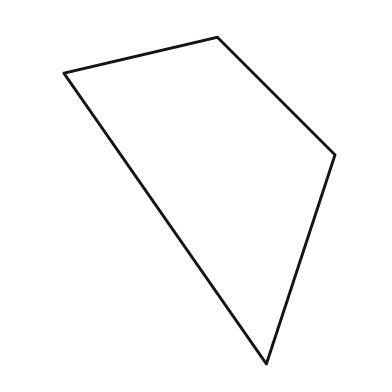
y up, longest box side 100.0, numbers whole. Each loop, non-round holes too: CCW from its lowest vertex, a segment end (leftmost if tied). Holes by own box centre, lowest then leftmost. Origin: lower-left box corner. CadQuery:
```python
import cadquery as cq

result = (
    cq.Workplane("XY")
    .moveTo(62.0, 0.0)
    .lineTo(83.0, 64.0)
    .lineTo(47.0, 100.0)
    .lineTo(0.0, 89.0)
    .close()
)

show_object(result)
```